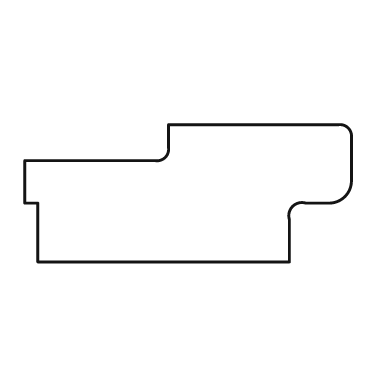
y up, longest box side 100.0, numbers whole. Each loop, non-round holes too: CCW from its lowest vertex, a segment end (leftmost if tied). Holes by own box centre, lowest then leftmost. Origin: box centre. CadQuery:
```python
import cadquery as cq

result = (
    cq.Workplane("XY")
    .moveTo(-46.0, -21.0)
    .lineTo(31.0, -21.0)
    .lineTo(31.0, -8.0)
    .threePointArc((32.0, -4.0), (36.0, -3.0))
    .lineTo(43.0, -3.0)
    .threePointArc((48.0, -1.0), (50.0, 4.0))
    .lineTo(50.0, 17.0)
    .threePointArc((49.0, 20.0), (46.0, 21.0))
    .lineTo(-6.0, 21.0)
    .lineTo(-6.0, 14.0)
    .threePointArc((-7.0, 11.0), (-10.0, 10.0))
    .lineTo(-50.0, 10.0)
    .lineTo(-50.0, -3.0)
    .lineTo(-46.0, -3.0)
    .close()
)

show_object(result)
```